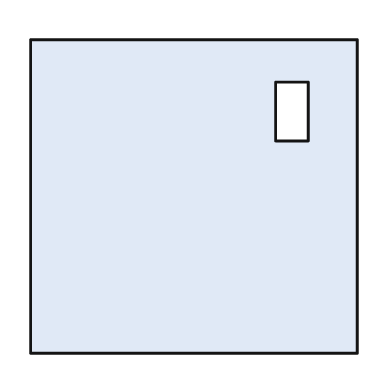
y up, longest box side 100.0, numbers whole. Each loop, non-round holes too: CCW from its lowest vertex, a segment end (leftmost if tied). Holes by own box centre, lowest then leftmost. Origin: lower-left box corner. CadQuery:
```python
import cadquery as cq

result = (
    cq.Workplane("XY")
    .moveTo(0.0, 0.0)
    .lineTo(100.0, 0.0)
    .lineTo(100.0, 96.0)
    .lineTo(0.0, 96.0)
    .close()
    .moveTo(75.0, 65.0)
    .lineTo(85.0, 65.0)
    .lineTo(85.0, 83.0)
    .lineTo(75.0, 83.0)
    .close()
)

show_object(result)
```